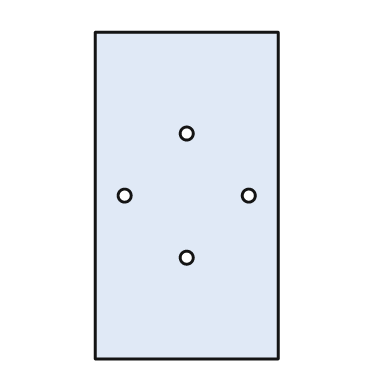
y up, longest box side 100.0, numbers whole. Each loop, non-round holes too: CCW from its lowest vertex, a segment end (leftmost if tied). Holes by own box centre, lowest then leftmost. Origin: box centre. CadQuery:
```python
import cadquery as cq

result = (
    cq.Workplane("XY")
    .moveTo(-28.0, -50.0)
    .lineTo(28.0, -50.0)
    .lineTo(28.0, 50.0)
    .lineTo(-28.0, 50.0)
    .close()
    .moveTo(0.0, -19.0)
    .circle(2.0)
    .moveTo(-19.0, 0.0)
    .circle(2.0)
    .moveTo(19.0, 0.0)
    .circle(2.0)
    .moveTo(0.0, 19.0)
    .circle(2.0)
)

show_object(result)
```